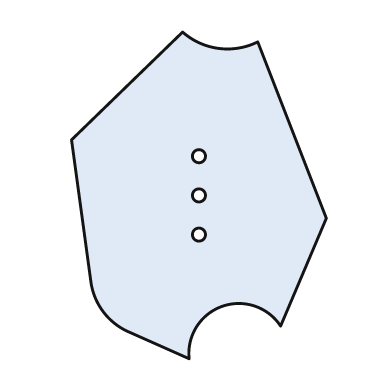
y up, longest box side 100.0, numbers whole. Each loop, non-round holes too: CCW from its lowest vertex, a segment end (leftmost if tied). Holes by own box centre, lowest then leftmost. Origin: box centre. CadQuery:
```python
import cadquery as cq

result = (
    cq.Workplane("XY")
    .moveTo(-3.0, -50.0)
    .threePointArc((7.0, -34.0), (25.0, -40.0))
    .lineTo(39.0, -7.0)
    .lineTo(18.0, 47.0)
    .threePointArc((6.0, 45.0), (-5.0, 50.0))
    .lineTo(-39.0, 17.0)
    .lineTo(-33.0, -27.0)
    .threePointArc((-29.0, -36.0), (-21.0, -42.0))
    .close()
    .moveTo(0.0, -12.0)
    .circle(2.0)
    .moveTo(0.0, 0.0)
    .circle(2.0)
    .moveTo(0.0, 12.0)
    .circle(2.0)
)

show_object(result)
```